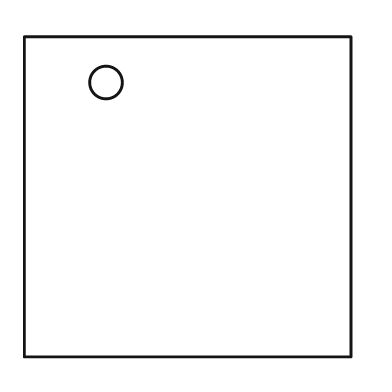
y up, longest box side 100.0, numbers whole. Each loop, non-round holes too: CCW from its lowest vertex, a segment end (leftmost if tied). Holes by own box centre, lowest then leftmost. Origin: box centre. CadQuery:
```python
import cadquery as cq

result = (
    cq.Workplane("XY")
    .moveTo(-50.0, -49.0)
    .lineTo(50.0, -49.0)
    .lineTo(50.0, 49.0)
    .lineTo(-50.0, 49.0)
    .close()
    .moveTo(-25.0, 35.0)
    .circle(5.0)
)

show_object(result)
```